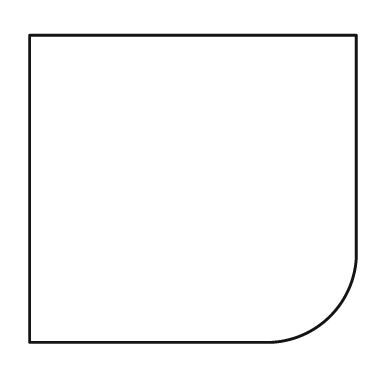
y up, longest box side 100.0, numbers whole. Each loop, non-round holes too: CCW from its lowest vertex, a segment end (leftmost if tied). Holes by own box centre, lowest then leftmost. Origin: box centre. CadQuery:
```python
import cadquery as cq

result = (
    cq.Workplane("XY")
    .moveTo(-50.0, -47.0)
    .lineTo(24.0, -47.0)
    .threePointArc((42.0, -39.0), (50.0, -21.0))
    .lineTo(50.0, 47.0)
    .lineTo(-50.0, 47.0)
    .close()
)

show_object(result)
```